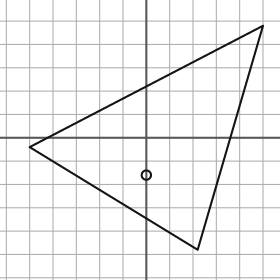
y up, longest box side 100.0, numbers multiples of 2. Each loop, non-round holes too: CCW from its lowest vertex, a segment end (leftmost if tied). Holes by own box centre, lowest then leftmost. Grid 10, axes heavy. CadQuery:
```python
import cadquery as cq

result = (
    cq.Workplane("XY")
    .moveTo(22.0, -48.0)
    .lineTo(50.0, 48.0)
    .lineTo(-50.0, -4.0)
    .close()
    .moveTo(0.0, -16.0)
    .circle(2.0)
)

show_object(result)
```